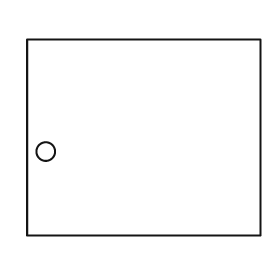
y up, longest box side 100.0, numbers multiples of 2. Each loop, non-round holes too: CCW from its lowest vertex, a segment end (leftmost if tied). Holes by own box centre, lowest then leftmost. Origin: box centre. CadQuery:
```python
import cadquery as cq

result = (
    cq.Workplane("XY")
    .moveTo(-50.0, -42.0)
    .lineTo(50.0, -42.0)
    .lineTo(50.0, 42.0)
    .lineTo(-50.0, 42.0)
    .close()
    .moveTo(-42.0, -6.0)
    .circle(4.0)
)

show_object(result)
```